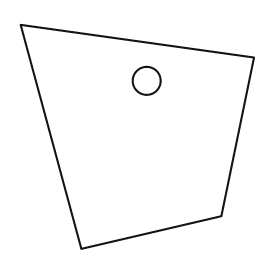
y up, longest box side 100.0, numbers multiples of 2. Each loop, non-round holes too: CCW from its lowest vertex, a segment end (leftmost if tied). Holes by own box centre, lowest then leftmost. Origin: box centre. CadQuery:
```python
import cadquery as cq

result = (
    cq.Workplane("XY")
    .moveTo(-24.0, -48.0)
    .lineTo(36.0, -34.0)
    .lineTo(50.0, 34.0)
    .lineTo(-50.0, 48.0)
    .close()
    .moveTo(4.0, 24.0)
    .circle(6.0)
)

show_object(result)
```